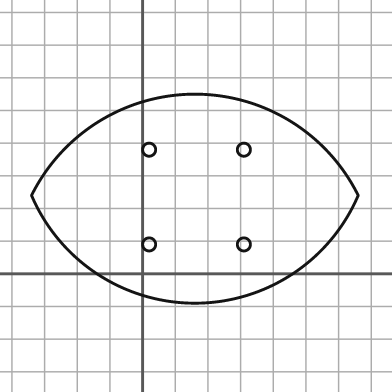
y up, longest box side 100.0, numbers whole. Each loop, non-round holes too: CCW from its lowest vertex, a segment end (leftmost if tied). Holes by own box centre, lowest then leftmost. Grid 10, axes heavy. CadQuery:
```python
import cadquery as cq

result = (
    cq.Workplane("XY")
    .moveTo(-34.0, 24.0)
    .threePointArc((16.0, -9.0), (66.0, 24.0))
    .threePointArc((16.0, 55.0), (-34.0, 24.0))
    .close()
    .moveTo(2.0, 9.0)
    .circle(2.0)
    .moveTo(31.0, 9.0)
    .circle(2.0)
    .moveTo(2.0, 38.0)
    .circle(2.0)
    .moveTo(31.0, 38.0)
    .circle(2.0)
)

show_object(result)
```